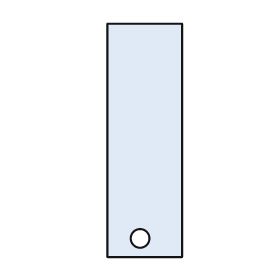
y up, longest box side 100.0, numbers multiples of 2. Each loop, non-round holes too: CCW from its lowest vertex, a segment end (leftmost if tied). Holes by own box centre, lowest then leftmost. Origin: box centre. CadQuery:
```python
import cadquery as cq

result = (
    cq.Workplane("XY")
    .moveTo(-16.0, -50.0)
    .lineTo(16.0, -50.0)
    .lineTo(16.0, 50.0)
    .lineTo(-16.0, 50.0)
    .close()
    .moveTo(-2.0, -42.0)
    .circle(4.0)
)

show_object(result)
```